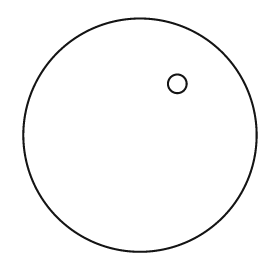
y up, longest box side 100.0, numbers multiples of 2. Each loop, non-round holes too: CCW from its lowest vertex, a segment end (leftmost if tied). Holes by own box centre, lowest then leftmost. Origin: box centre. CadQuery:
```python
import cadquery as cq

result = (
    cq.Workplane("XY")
    .moveTo(0.0, 0.0)
    .circle(50.0)
    .moveTo(16.0, 22.0)
    .circle(4.0)
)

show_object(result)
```